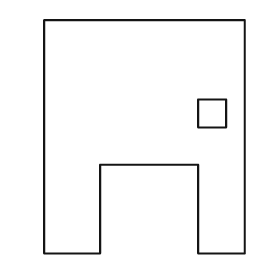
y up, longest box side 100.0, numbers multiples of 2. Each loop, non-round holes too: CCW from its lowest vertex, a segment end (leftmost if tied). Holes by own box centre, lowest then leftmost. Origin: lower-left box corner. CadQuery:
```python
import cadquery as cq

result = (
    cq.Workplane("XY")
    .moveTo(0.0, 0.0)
    .lineTo(24.0, 0.0)
    .lineTo(24.0, 38.0)
    .lineTo(66.0, 38.0)
    .lineTo(66.0, 0.0)
    .lineTo(86.0, 0.0)
    .lineTo(86.0, 100.0)
    .lineTo(0.0, 100.0)
    .close()
    .moveTo(66.0, 54.0)
    .lineTo(78.0, 54.0)
    .lineTo(78.0, 66.0)
    .lineTo(66.0, 66.0)
    .close()
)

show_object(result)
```